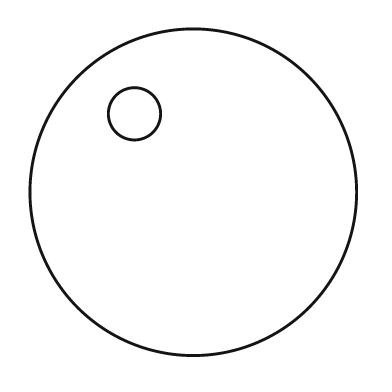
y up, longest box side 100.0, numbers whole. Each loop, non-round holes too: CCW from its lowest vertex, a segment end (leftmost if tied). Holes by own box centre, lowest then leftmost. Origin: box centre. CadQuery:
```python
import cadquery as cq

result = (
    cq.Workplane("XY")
    .moveTo(0.0, 0.0)
    .circle(50.0)
    .moveTo(-18.0, 24.0)
    .circle(8.0)
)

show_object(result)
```